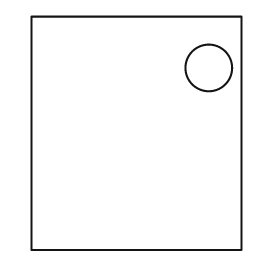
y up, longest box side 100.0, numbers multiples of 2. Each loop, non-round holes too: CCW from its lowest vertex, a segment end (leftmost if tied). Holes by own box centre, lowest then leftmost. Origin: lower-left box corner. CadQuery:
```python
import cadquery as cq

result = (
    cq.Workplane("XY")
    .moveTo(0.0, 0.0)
    .lineTo(90.0, 0.0)
    .lineTo(90.0, 100.0)
    .lineTo(0.0, 100.0)
    .close()
    .moveTo(76.0, 78.0)
    .circle(10.0)
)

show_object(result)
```